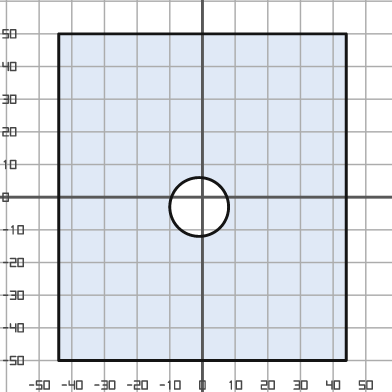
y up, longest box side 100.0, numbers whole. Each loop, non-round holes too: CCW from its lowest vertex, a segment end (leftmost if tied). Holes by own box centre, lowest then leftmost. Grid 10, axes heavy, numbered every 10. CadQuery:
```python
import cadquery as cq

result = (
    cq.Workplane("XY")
    .moveTo(-44.0, -50.0)
    .lineTo(44.0, -50.0)
    .lineTo(44.0, 50.0)
    .lineTo(-44.0, 50.0)
    .close()
    .moveTo(-1.0, -3.0)
    .circle(9.0)
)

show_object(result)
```